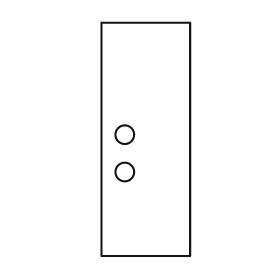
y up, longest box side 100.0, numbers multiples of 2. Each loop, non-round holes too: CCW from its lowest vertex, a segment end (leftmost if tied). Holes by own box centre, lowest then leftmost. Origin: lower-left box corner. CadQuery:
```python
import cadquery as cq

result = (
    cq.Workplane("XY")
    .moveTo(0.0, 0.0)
    .lineTo(38.0, 0.0)
    .lineTo(38.0, 100.0)
    .lineTo(0.0, 100.0)
    .close()
    .moveTo(10.0, 36.0)
    .circle(4.0)
    .moveTo(10.0, 52.0)
    .circle(4.0)
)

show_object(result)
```